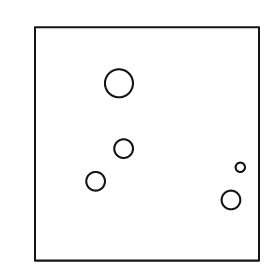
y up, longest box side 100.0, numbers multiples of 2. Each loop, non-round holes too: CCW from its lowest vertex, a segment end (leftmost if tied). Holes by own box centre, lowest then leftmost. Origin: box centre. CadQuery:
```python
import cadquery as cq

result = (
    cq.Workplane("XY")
    .moveTo(-48.0, -50.0)
    .lineTo(48.0, -50.0)
    .lineTo(48.0, 50.0)
    .lineTo(-48.0, 50.0)
    .close()
    .moveTo(36.0, -24.0)
    .circle(4.0)
    .moveTo(-22.0, -16.0)
    .circle(4.0)
    .moveTo(40.0, -10.0)
    .circle(2.0)
    .moveTo(-10.0, -2.0)
    .circle(4.0)
    .moveTo(-12.0, 26.0)
    .circle(6.0)
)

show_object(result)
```